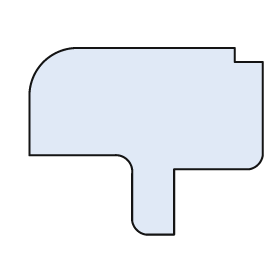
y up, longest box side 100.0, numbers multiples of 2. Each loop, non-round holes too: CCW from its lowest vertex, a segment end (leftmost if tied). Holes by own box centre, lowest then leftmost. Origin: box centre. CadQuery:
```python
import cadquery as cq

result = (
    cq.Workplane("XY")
    .moveTo(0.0, -40.0)
    .lineTo(12.0, -40.0)
    .lineTo(12.0, -12.0)
    .lineTo(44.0, -12.0)
    .threePointArc((48.0, -10.0), (50.0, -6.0))
    .lineTo(50.0, 34.0)
    .lineTo(38.0, 34.0)
    .lineTo(38.0, 40.0)
    .lineTo(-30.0, 40.0)
    .threePointArc((-44.0, 34.0), (-50.0, 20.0))
    .lineTo(-50.0, -6.0)
    .lineTo(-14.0, -6.0)
    .threePointArc((-8.0, -8.0), (-6.0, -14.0))
    .lineTo(-6.0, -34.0)
    .threePointArc((-4.0, -38.0), (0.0, -40.0))
    .close()
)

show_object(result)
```